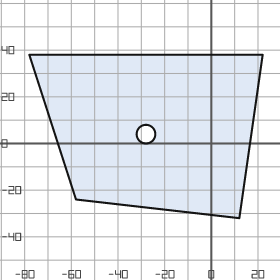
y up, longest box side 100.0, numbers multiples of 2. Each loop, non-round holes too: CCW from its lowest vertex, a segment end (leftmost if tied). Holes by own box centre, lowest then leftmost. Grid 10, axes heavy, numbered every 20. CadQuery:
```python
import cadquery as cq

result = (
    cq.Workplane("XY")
    .moveTo(12.0, -32.0)
    .lineTo(22.0, 38.0)
    .lineTo(-78.0, 38.0)
    .lineTo(-58.0, -24.0)
    .close()
    .moveTo(-28.0, 4.0)
    .circle(4.0)
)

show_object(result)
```